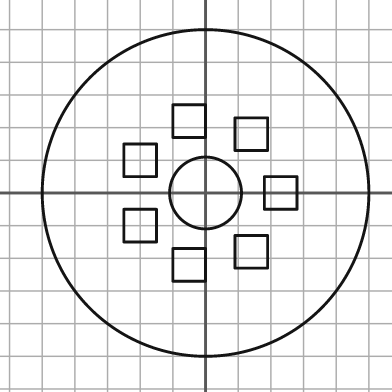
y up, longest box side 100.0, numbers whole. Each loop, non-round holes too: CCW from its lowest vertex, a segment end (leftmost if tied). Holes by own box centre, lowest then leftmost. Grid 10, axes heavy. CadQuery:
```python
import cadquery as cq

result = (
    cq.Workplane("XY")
    .moveTo(0.0, 0.0)
    .circle(50.0)
    .moveTo(-10.0, -27.0)
    .lineTo(0.0, -27.0)
    .lineTo(0.0, -17.0)
    .lineTo(-10.0, -17.0)
    .close()
    .moveTo(9.0, -23.0)
    .lineTo(19.0, -23.0)
    .lineTo(19.0, -13.0)
    .lineTo(9.0, -13.0)
    .close()
    .moveTo(-25.0, -15.0)
    .lineTo(-15.0, -15.0)
    .lineTo(-15.0, -5.0)
    .lineTo(-25.0, -5.0)
    .close()
    .moveTo(0.0, 0.0)
    .circle(11.0)
    .moveTo(18.0, -5.0)
    .lineTo(28.0, -5.0)
    .lineTo(28.0, 5.0)
    .lineTo(18.0, 5.0)
    .close()
    .moveTo(-25.0, 5.0)
    .lineTo(-15.0, 5.0)
    .lineTo(-15.0, 15.0)
    .lineTo(-25.0, 15.0)
    .close()
    .moveTo(9.0, 13.0)
    .lineTo(19.0, 13.0)
    .lineTo(19.0, 23.0)
    .lineTo(9.0, 23.0)
    .close()
    .moveTo(-10.0, 17.0)
    .lineTo(0.0, 17.0)
    .lineTo(0.0, 27.0)
    .lineTo(-10.0, 27.0)
    .close()
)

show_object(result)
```